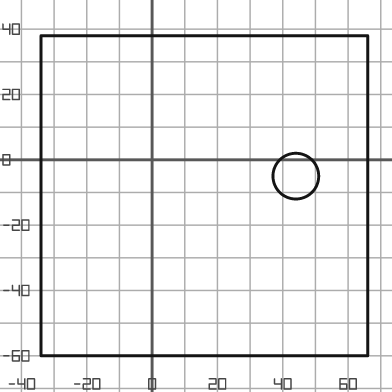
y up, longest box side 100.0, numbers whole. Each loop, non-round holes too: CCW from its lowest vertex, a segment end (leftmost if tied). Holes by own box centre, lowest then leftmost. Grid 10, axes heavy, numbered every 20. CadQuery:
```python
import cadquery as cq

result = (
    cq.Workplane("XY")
    .moveTo(-34.0, -60.0)
    .lineTo(66.0, -60.0)
    .lineTo(66.0, 38.0)
    .lineTo(-34.0, 38.0)
    .close()
    .moveTo(44.0, -5.0)
    .circle(7.0)
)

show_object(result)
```